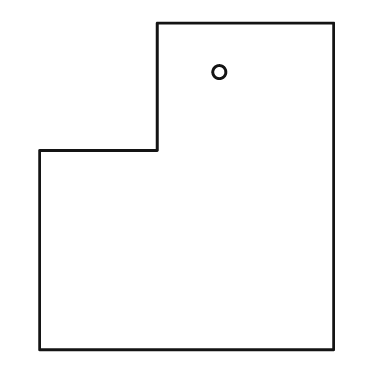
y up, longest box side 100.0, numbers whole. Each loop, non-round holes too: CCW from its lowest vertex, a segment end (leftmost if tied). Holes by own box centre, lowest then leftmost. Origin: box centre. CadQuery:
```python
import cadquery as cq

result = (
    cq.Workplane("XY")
    .moveTo(-45.0, -50.0)
    .lineTo(45.0, -50.0)
    .lineTo(45.0, 50.0)
    .lineTo(-9.0, 50.0)
    .lineTo(-9.0, 11.0)
    .lineTo(-45.0, 11.0)
    .close()
    .moveTo(10.0, 35.0)
    .circle(2.0)
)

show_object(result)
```